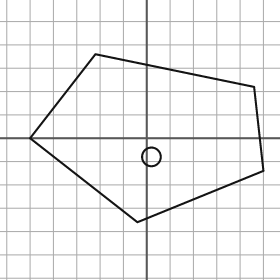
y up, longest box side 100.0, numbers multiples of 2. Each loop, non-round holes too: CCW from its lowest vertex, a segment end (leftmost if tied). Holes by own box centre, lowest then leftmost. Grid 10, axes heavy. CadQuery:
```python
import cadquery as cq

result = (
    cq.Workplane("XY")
    .moveTo(-4.0, -36.0)
    .lineTo(50.0, -14.0)
    .lineTo(46.0, 22.0)
    .lineTo(-22.0, 36.0)
    .lineTo(-50.0, 0.0)
    .close()
    .moveTo(2.0, -8.0)
    .circle(4.0)
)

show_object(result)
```